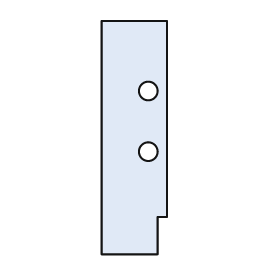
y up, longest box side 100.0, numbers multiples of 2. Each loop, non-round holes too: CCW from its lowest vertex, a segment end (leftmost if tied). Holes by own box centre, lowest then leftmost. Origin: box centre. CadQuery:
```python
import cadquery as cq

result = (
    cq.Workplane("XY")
    .moveTo(-14.0, -50.0)
    .lineTo(10.0, -50.0)
    .lineTo(10.0, -34.0)
    .lineTo(14.0, -34.0)
    .lineTo(14.0, 50.0)
    .lineTo(-14.0, 50.0)
    .close()
    .moveTo(6.0, -6.0)
    .circle(4.0)
    .moveTo(6.0, 20.0)
    .circle(4.0)
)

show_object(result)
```